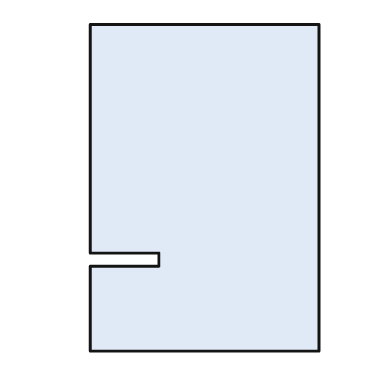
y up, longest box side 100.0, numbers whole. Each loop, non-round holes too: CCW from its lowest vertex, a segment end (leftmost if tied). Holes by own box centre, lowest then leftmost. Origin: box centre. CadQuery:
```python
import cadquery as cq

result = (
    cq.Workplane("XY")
    .moveTo(-35.0, -50.0)
    .lineTo(35.0, -50.0)
    .lineTo(35.0, 50.0)
    .lineTo(-35.0, 50.0)
    .lineTo(-35.0, -20.0)
    .lineTo(-14.0, -20.0)
    .lineTo(-14.0, -24.0)
    .lineTo(-35.0, -24.0)
    .close()
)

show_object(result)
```